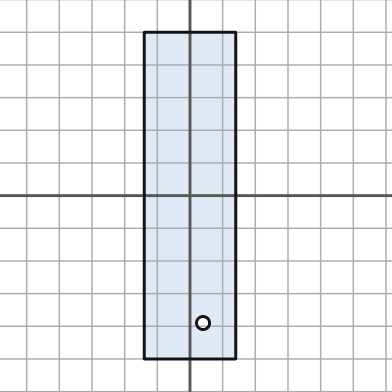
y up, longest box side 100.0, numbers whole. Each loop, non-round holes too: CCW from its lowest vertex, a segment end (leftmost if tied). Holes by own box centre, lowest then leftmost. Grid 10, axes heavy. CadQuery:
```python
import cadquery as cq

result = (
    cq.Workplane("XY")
    .moveTo(-14.0, -50.0)
    .lineTo(14.0, -50.0)
    .lineTo(14.0, 50.0)
    .lineTo(-14.0, 50.0)
    .close()
    .moveTo(4.0, -39.0)
    .circle(2.0)
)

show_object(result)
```